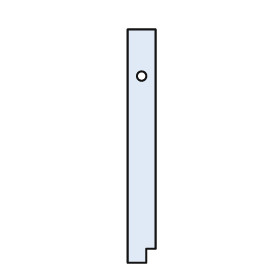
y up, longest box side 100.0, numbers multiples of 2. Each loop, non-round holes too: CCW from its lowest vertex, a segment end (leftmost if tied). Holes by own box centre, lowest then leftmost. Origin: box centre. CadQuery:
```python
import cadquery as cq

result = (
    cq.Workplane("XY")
    .moveTo(-6.0, -50.0)
    .lineTo(2.0, -50.0)
    .lineTo(2.0, -44.0)
    .lineTo(6.0, -44.0)
    .lineTo(6.0, 50.0)
    .lineTo(-6.0, 50.0)
    .close()
    .moveTo(0.0, 30.0)
    .circle(2.0)
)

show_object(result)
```